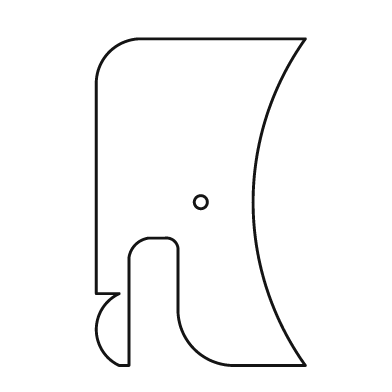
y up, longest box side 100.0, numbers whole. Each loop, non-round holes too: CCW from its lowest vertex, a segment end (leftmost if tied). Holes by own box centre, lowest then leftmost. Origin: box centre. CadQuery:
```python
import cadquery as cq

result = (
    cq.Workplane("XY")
    .moveTo(-25.0, -50.0)
    .lineTo(-22.0, -50.0)
    .lineTo(-22.0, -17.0)
    .threePointArc((-20.0, -13.0), (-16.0, -11.0))
    .lineTo(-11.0, -11.0)
    .threePointArc((-8.0, -12.0), (-7.0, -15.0))
    .lineTo(-7.0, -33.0)
    .threePointArc((-2.0, -45.0), (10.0, -50.0))
    .lineTo(32.0, -50.0)
    .threePointArc((16.0, 0.0), (32.0, 50.0))
    .lineTo(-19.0, 50.0)
    .threePointArc((-28.0, 46.0), (-32.0, 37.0))
    .lineTo(-32.0, -28.0)
    .lineTo(-25.0, -28.0)
    .threePointArc((-32.0, -39.0), (-25.0, -50.0))
    .close()
    .moveTo(0.0, 0.0)
    .circle(2.0)
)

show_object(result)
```